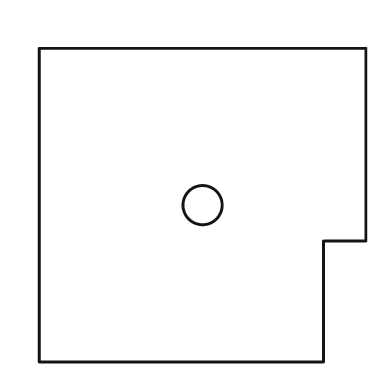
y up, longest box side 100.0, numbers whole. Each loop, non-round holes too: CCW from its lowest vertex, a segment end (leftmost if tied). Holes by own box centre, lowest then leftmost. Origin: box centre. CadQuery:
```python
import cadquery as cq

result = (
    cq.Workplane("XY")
    .moveTo(-50.0, -48.0)
    .lineTo(37.0, -48.0)
    .lineTo(37.0, -11.0)
    .lineTo(50.0, -11.0)
    .lineTo(50.0, 48.0)
    .lineTo(-50.0, 48.0)
    .close()
    .moveTo(0.0, 0.0)
    .circle(6.0)
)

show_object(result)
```